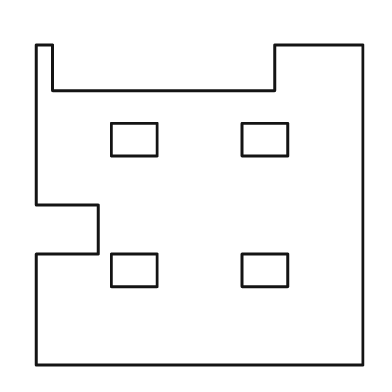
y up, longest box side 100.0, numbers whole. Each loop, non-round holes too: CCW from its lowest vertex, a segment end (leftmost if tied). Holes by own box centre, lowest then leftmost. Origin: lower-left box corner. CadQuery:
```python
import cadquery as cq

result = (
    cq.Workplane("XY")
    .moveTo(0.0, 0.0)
    .lineTo(100.0, 0.0)
    .lineTo(100.0, 98.0)
    .lineTo(73.0, 98.0)
    .lineTo(73.0, 84.0)
    .lineTo(5.0, 84.0)
    .lineTo(5.0, 98.0)
    .lineTo(0.0, 98.0)
    .lineTo(0.0, 49.0)
    .lineTo(19.0, 49.0)
    .lineTo(19.0, 34.0)
    .lineTo(0.0, 34.0)
    .close()
    .moveTo(23.0, 24.0)
    .lineTo(37.0, 24.0)
    .lineTo(37.0, 34.0)
    .lineTo(23.0, 34.0)
    .close()
    .moveTo(63.0, 24.0)
    .lineTo(77.0, 24.0)
    .lineTo(77.0, 34.0)
    .lineTo(63.0, 34.0)
    .close()
    .moveTo(23.0, 64.0)
    .lineTo(37.0, 64.0)
    .lineTo(37.0, 74.0)
    .lineTo(23.0, 74.0)
    .close()
    .moveTo(63.0, 64.0)
    .lineTo(77.0, 64.0)
    .lineTo(77.0, 74.0)
    .lineTo(63.0, 74.0)
    .close()
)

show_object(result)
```